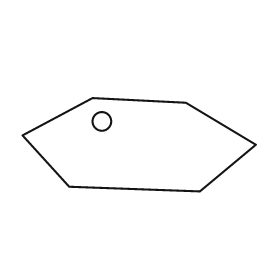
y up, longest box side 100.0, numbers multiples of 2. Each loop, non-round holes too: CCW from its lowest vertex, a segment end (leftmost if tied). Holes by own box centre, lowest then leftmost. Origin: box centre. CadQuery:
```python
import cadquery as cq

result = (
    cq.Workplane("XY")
    .moveTo(26.0, -20.0)
    .lineTo(50.0, 0.0)
    .lineTo(20.0, 18.0)
    .lineTo(-20.0, 20.0)
    .lineTo(-50.0, 4.0)
    .lineTo(-30.0, -18.0)
    .close()
    .moveTo(-16.0, 10.0)
    .circle(4.0)
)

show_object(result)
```